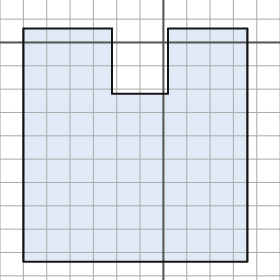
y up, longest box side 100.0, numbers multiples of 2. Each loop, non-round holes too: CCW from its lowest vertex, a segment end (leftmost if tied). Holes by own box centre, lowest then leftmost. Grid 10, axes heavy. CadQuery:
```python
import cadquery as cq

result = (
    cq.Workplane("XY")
    .moveTo(-60.0, -94.0)
    .lineTo(36.0, -94.0)
    .lineTo(36.0, 6.0)
    .lineTo(2.0, 6.0)
    .lineTo(2.0, -22.0)
    .lineTo(-22.0, -22.0)
    .lineTo(-22.0, 6.0)
    .lineTo(-60.0, 6.0)
    .close()
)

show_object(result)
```